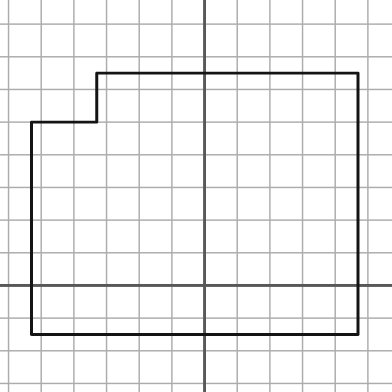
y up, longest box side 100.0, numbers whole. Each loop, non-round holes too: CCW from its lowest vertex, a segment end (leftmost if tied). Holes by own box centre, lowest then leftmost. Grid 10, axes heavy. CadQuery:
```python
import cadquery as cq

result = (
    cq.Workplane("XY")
    .moveTo(-53.0, -15.0)
    .lineTo(47.0, -15.0)
    .lineTo(47.0, 65.0)
    .lineTo(-33.0, 65.0)
    .lineTo(-33.0, 50.0)
    .lineTo(-53.0, 50.0)
    .close()
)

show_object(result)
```